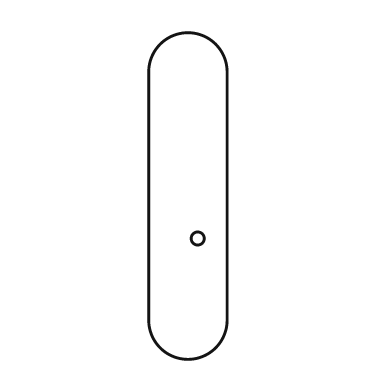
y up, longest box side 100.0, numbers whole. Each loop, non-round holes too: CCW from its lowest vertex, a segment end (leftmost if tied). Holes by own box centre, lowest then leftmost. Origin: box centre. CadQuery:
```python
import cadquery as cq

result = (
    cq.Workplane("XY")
    .moveTo(-12.0, -38.0)
    .threePointArc((0.0, -50.0), (12.0, -38.0))
    .lineTo(12.0, 38.0)
    .threePointArc((0.0, 50.0), (-12.0, 38.0))
    .close()
    .moveTo(3.0, -13.0)
    .circle(2.0)
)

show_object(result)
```